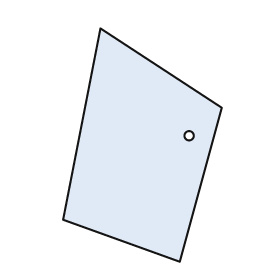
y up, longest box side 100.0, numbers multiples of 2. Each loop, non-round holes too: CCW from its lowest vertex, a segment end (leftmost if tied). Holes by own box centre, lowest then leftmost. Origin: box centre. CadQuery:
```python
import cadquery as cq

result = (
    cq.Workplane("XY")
    .moveTo(16.0, -50.0)
    .lineTo(34.0, 16.0)
    .lineTo(-18.0, 50.0)
    .lineTo(-34.0, -32.0)
    .close()
    .moveTo(20.0, 4.0)
    .circle(2.0)
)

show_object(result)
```